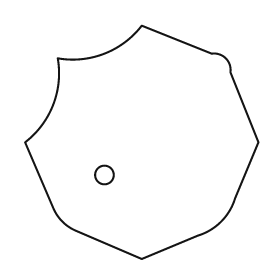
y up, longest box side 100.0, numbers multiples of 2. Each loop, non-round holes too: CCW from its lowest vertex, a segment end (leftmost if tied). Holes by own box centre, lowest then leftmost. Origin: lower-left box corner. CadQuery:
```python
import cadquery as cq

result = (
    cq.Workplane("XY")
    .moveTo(50.0, 0.0)
    .lineTo(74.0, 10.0)
    .threePointArc((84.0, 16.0), (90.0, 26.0))
    .lineTo(100.0, 50.0)
    .lineTo(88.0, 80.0)
    .threePointArc((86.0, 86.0), (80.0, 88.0))
    .lineTo(50.0, 100.0)
    .threePointArc((34.0, 88.0), (14.0, 86.0))
    .threePointArc((12.0, 66.0), (0.0, 50.0))
    .lineTo(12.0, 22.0)
    .threePointArc((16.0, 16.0), (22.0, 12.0))
    .close()
    .moveTo(34.0, 36.0)
    .circle(4.0)
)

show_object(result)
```